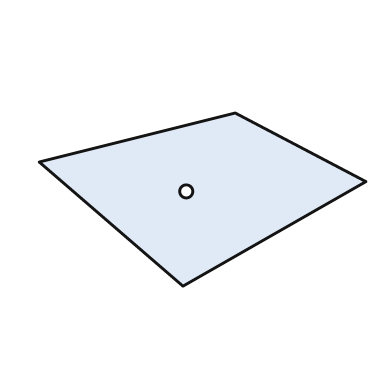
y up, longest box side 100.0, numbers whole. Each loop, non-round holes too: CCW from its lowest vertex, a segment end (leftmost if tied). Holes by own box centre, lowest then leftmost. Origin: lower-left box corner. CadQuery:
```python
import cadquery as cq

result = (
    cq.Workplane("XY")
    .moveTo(44.0, 0.0)
    .lineTo(100.0, 32.0)
    .lineTo(60.0, 53.0)
    .lineTo(0.0, 38.0)
    .close()
    .moveTo(45.0, 29.0)
    .circle(2.0)
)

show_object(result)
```